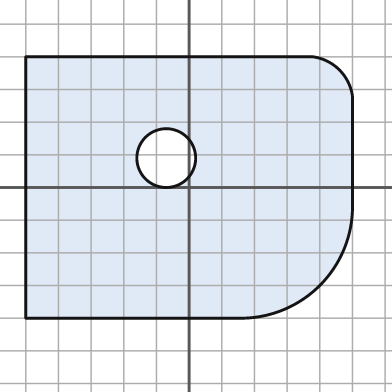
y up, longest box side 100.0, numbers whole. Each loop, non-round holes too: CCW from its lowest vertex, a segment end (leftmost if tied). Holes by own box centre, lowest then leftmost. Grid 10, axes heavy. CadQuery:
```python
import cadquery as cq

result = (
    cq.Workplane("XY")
    .moveTo(-50.0, -40.0)
    .lineTo(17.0, -40.0)
    .threePointArc((40.0, -30.0), (50.0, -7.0))
    .lineTo(50.0, 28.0)
    .threePointArc((46.0, 36.0), (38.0, 40.0))
    .lineTo(-50.0, 40.0)
    .close()
    .moveTo(-7.0, 9.0)
    .circle(9.0)
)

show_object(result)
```